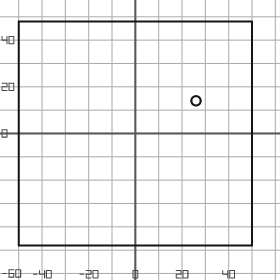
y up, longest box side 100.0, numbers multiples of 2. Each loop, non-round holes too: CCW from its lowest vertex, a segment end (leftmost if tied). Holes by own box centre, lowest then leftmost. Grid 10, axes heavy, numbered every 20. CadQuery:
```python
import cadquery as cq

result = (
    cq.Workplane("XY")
    .moveTo(-50.0, -48.0)
    .lineTo(50.0, -48.0)
    .lineTo(50.0, 48.0)
    .lineTo(-50.0, 48.0)
    .close()
    .moveTo(26.0, 14.0)
    .circle(2.0)
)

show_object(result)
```